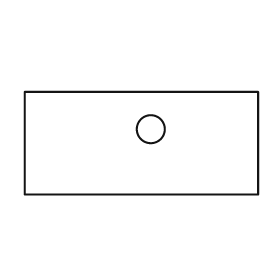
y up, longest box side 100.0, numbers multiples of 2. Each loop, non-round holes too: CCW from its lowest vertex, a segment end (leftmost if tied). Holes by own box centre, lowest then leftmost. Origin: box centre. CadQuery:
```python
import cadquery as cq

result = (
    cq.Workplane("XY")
    .moveTo(-50.0, -22.0)
    .lineTo(50.0, -22.0)
    .lineTo(50.0, 22.0)
    .lineTo(-50.0, 22.0)
    .close()
    .moveTo(4.0, 6.0)
    .circle(6.0)
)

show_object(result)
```